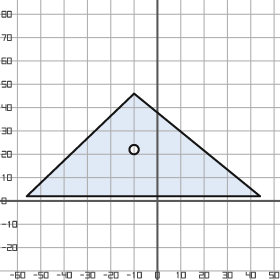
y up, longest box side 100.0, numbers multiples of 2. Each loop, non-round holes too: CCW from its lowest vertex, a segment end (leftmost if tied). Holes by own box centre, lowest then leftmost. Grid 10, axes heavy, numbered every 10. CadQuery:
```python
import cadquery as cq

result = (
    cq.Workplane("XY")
    .moveTo(-56.0, 2.0)
    .lineTo(44.0, 2.0)
    .lineTo(-10.0, 46.0)
    .close()
    .moveTo(-10.0, 22.0)
    .circle(2.0)
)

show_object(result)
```